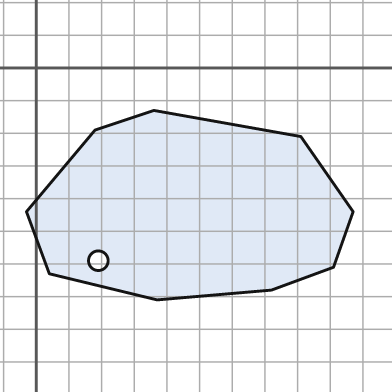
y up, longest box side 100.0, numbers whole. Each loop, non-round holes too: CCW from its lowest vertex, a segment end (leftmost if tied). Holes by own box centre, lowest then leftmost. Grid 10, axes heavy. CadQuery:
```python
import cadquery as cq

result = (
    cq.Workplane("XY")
    .moveTo(37.0, -71.0)
    .lineTo(72.0, -68.0)
    .lineTo(91.0, -61.0)
    .lineTo(97.0, -44.0)
    .lineTo(81.0, -21.0)
    .lineTo(36.0, -13.0)
    .lineTo(18.0, -19.0)
    .lineTo(-3.0, -44.0)
    .lineTo(4.0, -63.0)
    .close()
    .moveTo(19.0, -59.0)
    .circle(3.0)
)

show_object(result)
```